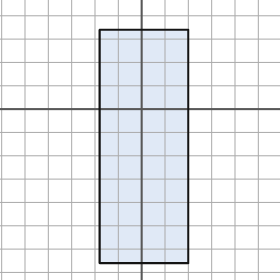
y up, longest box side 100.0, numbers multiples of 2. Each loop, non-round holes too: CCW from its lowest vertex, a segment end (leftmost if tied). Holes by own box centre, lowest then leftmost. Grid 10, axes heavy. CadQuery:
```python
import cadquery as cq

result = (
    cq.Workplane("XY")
    .moveTo(-18.0, -66.0)
    .lineTo(20.0, -66.0)
    .lineTo(20.0, 34.0)
    .lineTo(-18.0, 34.0)
    .close()
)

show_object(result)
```